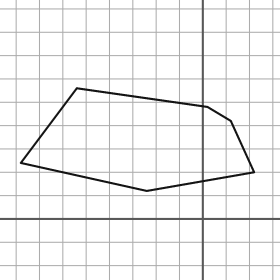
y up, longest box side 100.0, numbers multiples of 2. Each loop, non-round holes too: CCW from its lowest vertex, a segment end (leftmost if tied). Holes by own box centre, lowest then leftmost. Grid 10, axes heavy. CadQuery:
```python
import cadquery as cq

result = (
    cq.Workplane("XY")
    .moveTo(-24.0, 12.0)
    .lineTo(22.0, 20.0)
    .lineTo(12.0, 42.0)
    .lineTo(2.0, 48.0)
    .lineTo(-54.0, 56.0)
    .lineTo(-78.0, 24.0)
    .close()
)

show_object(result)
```